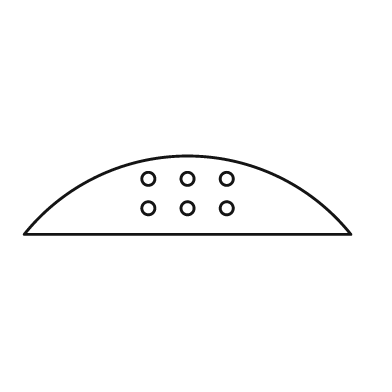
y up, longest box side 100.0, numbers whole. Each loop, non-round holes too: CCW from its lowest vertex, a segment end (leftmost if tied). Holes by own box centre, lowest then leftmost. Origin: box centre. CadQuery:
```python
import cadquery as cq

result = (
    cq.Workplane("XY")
    .moveTo(-50.0, -12.0)
    .lineTo(50.0, -12.0)
    .threePointArc((0.0, 12.0), (-50.0, -12.0))
    .close()
    .moveTo(-12.0, -4.0)
    .circle(2.0)
    .moveTo(0.0, -4.0)
    .circle(2.0)
    .moveTo(12.0, -4.0)
    .circle(2.0)
    .moveTo(-12.0, 5.0)
    .circle(2.0)
    .moveTo(0.0, 5.0)
    .circle(2.0)
    .moveTo(12.0, 5.0)
    .circle(2.0)
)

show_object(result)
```